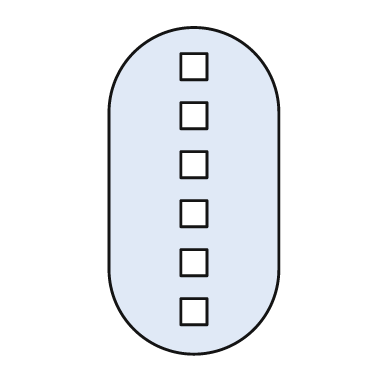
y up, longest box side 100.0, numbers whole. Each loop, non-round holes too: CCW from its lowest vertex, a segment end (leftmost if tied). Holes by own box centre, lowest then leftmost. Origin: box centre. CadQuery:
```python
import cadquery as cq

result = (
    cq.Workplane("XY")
    .moveTo(-26.0, -24.0)
    .threePointArc((0.0, -50.0), (26.0, -24.0))
    .lineTo(26.0, 24.0)
    .threePointArc((0.0, 50.0), (-26.0, 24.0))
    .close()
    .moveTo(-4.0, -41.0)
    .lineTo(4.0, -41.0)
    .lineTo(4.0, -33.0)
    .lineTo(-4.0, -33.0)
    .close()
    .moveTo(-4.0, -26.0)
    .lineTo(4.0, -26.0)
    .lineTo(4.0, -18.0)
    .lineTo(-4.0, -18.0)
    .close()
    .moveTo(-4.0, -11.0)
    .lineTo(4.0, -11.0)
    .lineTo(4.0, -3.0)
    .lineTo(-4.0, -3.0)
    .close()
    .moveTo(-4.0, 4.0)
    .lineTo(4.0, 4.0)
    .lineTo(4.0, 12.0)
    .lineTo(-4.0, 12.0)
    .close()
    .moveTo(-4.0, 19.0)
    .lineTo(4.0, 19.0)
    .lineTo(4.0, 27.0)
    .lineTo(-4.0, 27.0)
    .close()
    .moveTo(-4.0, 34.0)
    .lineTo(4.0, 34.0)
    .lineTo(4.0, 42.0)
    .lineTo(-4.0, 42.0)
    .close()
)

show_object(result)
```